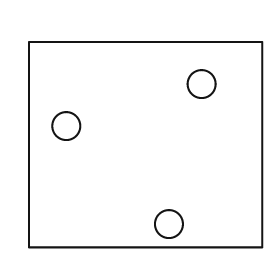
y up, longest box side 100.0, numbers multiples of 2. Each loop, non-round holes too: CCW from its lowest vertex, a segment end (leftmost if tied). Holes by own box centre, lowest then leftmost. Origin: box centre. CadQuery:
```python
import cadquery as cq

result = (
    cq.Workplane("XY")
    .moveTo(-50.0, -44.0)
    .lineTo(50.0, -44.0)
    .lineTo(50.0, 44.0)
    .lineTo(-50.0, 44.0)
    .close()
    .moveTo(10.0, -34.0)
    .circle(6.0)
    .moveTo(-34.0, 8.0)
    .circle(6.0)
    .moveTo(24.0, 26.0)
    .circle(6.0)
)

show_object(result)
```